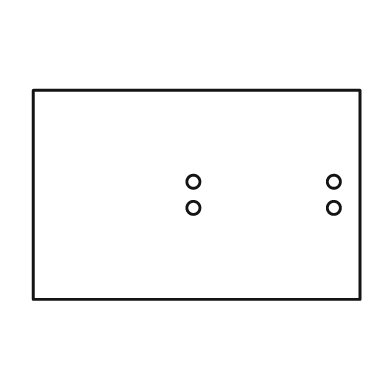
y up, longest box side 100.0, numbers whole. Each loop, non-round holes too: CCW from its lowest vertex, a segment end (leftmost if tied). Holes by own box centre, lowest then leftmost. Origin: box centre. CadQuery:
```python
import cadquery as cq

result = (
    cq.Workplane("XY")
    .moveTo(-50.0, -32.0)
    .lineTo(50.0, -32.0)
    .lineTo(50.0, 32.0)
    .lineTo(-50.0, 32.0)
    .close()
    .moveTo(-1.0, -4.0)
    .circle(2.0)
    .moveTo(42.0, -4.0)
    .circle(2.0)
    .moveTo(-1.0, 4.0)
    .circle(2.0)
    .moveTo(42.0, 4.0)
    .circle(2.0)
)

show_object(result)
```